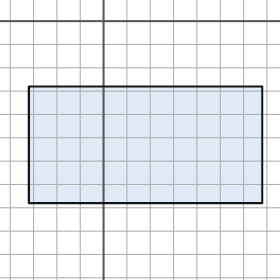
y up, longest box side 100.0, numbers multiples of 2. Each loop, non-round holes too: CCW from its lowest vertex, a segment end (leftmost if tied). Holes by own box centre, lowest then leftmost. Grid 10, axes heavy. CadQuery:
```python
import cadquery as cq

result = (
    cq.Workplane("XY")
    .moveTo(-32.0, -78.0)
    .lineTo(68.0, -78.0)
    .lineTo(68.0, -28.0)
    .lineTo(-32.0, -28.0)
    .close()
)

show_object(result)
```